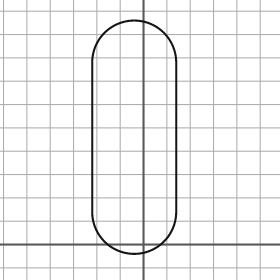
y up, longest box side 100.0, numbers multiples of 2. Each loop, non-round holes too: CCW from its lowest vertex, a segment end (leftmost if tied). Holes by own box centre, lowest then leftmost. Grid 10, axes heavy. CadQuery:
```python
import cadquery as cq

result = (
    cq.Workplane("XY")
    .moveTo(-22.0, 14.0)
    .threePointArc((-4.0, -4.0), (14.0, 14.0))
    .lineTo(14.0, 78.0)
    .threePointArc((-4.0, 96.0), (-22.0, 78.0))
    .close()
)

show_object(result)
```